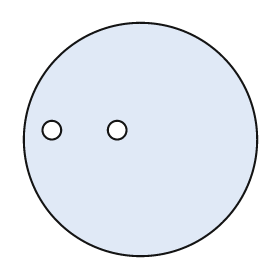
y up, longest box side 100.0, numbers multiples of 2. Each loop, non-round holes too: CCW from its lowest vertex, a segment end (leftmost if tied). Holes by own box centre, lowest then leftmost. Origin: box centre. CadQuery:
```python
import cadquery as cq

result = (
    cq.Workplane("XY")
    .moveTo(0.0, 0.0)
    .circle(50.0)
    .moveTo(-38.0, 4.0)
    .circle(4.0)
    .moveTo(-10.0, 4.0)
    .circle(4.0)
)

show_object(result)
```